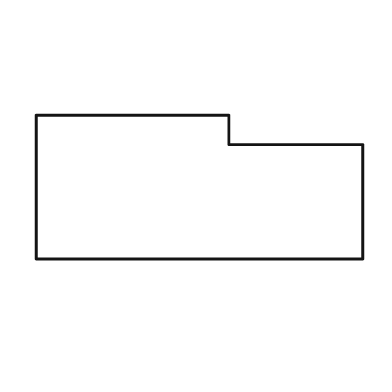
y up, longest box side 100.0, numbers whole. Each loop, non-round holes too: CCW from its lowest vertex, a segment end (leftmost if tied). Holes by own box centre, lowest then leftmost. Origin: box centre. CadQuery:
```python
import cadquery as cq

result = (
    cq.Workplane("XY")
    .moveTo(-50.0, -22.0)
    .lineTo(50.0, -22.0)
    .lineTo(50.0, 13.0)
    .lineTo(9.0, 13.0)
    .lineTo(9.0, 22.0)
    .lineTo(-50.0, 22.0)
    .close()
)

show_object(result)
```